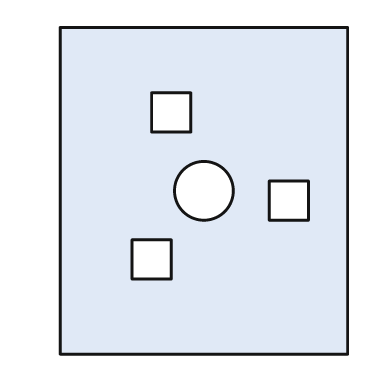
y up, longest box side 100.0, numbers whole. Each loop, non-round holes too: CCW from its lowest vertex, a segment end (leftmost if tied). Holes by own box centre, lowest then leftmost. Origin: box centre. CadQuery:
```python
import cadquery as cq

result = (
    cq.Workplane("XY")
    .moveTo(-44.0, -50.0)
    .lineTo(44.0, -50.0)
    .lineTo(44.0, 50.0)
    .lineTo(-44.0, 50.0)
    .close()
    .moveTo(-22.0, -27.0)
    .lineTo(-10.0, -27.0)
    .lineTo(-10.0, -15.0)
    .lineTo(-22.0, -15.0)
    .close()
    .moveTo(20.0, -9.0)
    .lineTo(32.0, -9.0)
    .lineTo(32.0, 3.0)
    .lineTo(20.0, 3.0)
    .close()
    .moveTo(0.0, 0.0)
    .circle(9.0)
    .moveTo(-16.0, 18.0)
    .lineTo(-4.0, 18.0)
    .lineTo(-4.0, 30.0)
    .lineTo(-16.0, 30.0)
    .close()
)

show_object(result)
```